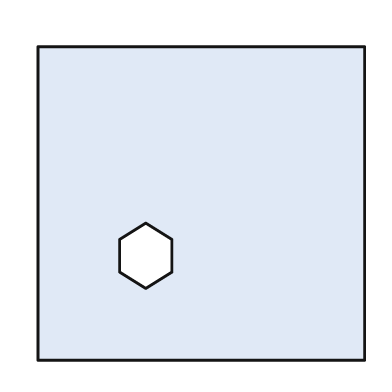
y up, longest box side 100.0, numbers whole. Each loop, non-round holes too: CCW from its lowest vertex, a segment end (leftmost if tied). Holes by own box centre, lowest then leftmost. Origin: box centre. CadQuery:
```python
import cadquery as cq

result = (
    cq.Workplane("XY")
    .moveTo(-50.0, -48.0)
    .lineTo(50.0, -48.0)
    .lineTo(50.0, 48.0)
    .lineTo(-50.0, 48.0)
    .close()
    .moveTo(-17.0, -26.0)
    .lineTo(-9.0, -21.0)
    .lineTo(-9.0, -11.0)
    .lineTo(-17.0, -6.0)
    .lineTo(-25.0, -11.0)
    .lineTo(-25.0, -21.0)
    .close()
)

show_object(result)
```